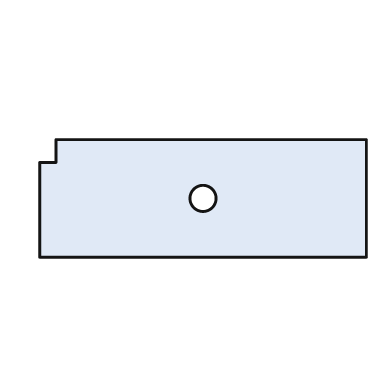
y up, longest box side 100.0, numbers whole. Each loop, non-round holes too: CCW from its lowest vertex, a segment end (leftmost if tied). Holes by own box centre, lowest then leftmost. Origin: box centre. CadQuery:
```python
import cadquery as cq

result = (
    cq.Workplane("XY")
    .moveTo(-50.0, -18.0)
    .lineTo(50.0, -18.0)
    .lineTo(50.0, 18.0)
    .lineTo(-45.0, 18.0)
    .lineTo(-45.0, 11.0)
    .lineTo(-50.0, 11.0)
    .close()
    .moveTo(0.0, 0.0)
    .circle(4.0)
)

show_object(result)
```